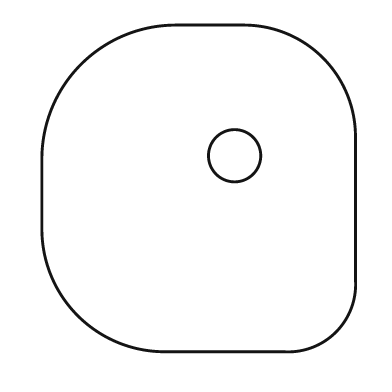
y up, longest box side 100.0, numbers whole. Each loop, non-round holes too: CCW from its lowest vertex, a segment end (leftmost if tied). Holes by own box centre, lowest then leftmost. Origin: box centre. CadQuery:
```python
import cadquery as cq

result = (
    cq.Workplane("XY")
    .moveTo(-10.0, -50.0)
    .lineTo(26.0, -50.0)
    .threePointArc((42.0, -44.0), (48.0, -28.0))
    .lineTo(48.0, 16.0)
    .threePointArc((38.0, 40.0), (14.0, 50.0))
    .lineTo(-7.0, 50.0)
    .threePointArc((-36.0, 38.0), (-48.0, 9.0))
    .lineTo(-48.0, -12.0)
    .threePointArc((-37.0, -39.0), (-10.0, -50.0))
    .close()
    .moveTo(11.0, 10.0)
    .circle(8.0)
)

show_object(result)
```